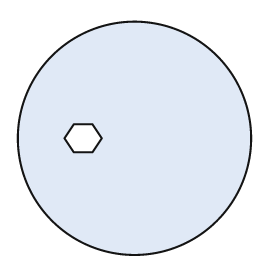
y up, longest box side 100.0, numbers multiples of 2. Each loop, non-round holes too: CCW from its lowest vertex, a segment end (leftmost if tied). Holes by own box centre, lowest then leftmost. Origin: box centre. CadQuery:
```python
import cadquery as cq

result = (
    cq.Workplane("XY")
    .moveTo(0.0, 0.0)
    .circle(50.0)
    .moveTo(-26.0, -6.0)
    .lineTo(-18.0, -6.0)
    .lineTo(-14.0, 0.0)
    .lineTo(-18.0, 6.0)
    .lineTo(-26.0, 6.0)
    .lineTo(-30.0, 0.0)
    .close()
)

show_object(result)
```